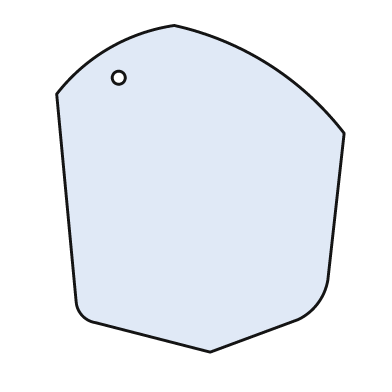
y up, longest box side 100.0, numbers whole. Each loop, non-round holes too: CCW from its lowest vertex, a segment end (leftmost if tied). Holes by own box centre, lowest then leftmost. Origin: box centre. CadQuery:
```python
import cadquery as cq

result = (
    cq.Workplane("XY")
    .moveTo(3.0, -50.0)
    .lineTo(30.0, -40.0)
    .threePointArc((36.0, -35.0), (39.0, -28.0))
    .lineTo(44.0, 17.0)
    .threePointArc((21.0, 38.0), (-8.0, 50.0))
    .threePointArc((-28.0, 43.0), (-44.0, 29.0))
    .lineTo(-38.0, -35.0)
    .threePointArc((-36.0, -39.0), (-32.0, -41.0))
    .close()
    .moveTo(-25.0, 34.0)
    .circle(2.0)
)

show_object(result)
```